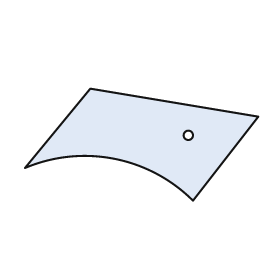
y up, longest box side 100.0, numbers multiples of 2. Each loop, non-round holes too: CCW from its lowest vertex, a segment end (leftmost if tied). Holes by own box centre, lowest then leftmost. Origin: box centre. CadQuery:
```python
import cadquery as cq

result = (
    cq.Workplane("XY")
    .moveTo(22.0, -24.0)
    .lineTo(50.0, 12.0)
    .lineTo(-22.0, 24.0)
    .lineTo(-50.0, -10.0)
    .threePointArc((-12.0, -6.0), (22.0, -24.0))
    .close()
    .moveTo(20.0, 4.0)
    .circle(2.0)
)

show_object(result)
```